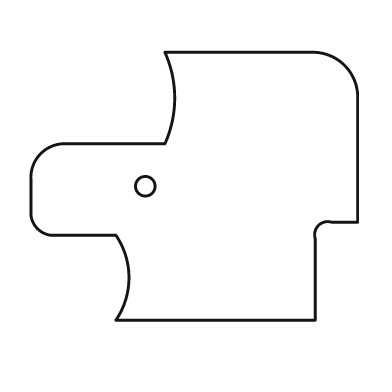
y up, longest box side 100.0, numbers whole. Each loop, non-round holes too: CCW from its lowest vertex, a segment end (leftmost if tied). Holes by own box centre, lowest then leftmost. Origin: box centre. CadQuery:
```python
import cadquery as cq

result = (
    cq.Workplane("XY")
    .moveTo(-24.0, -41.0)
    .lineTo(37.0, -41.0)
    .lineTo(37.0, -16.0)
    .threePointArc((38.0, -12.0), (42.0, -11.0))
    .lineTo(50.0, -11.0)
    .lineTo(50.0, 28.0)
    .threePointArc((46.0, 37.0), (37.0, 41.0))
    .lineTo(-9.0, 41.0)
    .threePointArc((-6.0, 27.0), (-9.0, 13.0))
    .lineTo(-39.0, 13.0)
    .threePointArc((-47.0, 10.0), (-50.0, 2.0))
    .lineTo(-50.0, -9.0)
    .threePointArc((-48.0, -13.0), (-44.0, -15.0))
    .lineTo(-24.0, -15.0)
    .threePointArc((-20.0, -28.0), (-24.0, -41.0))
    .close()
    .moveTo(-15.0, 0.0)
    .circle(3.0)
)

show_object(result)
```